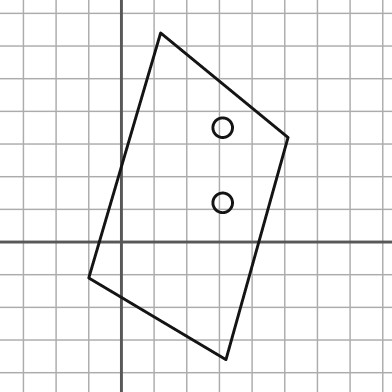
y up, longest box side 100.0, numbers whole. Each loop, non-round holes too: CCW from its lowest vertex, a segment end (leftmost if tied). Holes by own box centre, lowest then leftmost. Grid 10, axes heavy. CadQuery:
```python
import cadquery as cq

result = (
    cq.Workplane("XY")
    .moveTo(32.0, -36.0)
    .lineTo(51.0, 32.0)
    .lineTo(12.0, 64.0)
    .lineTo(-10.0, -11.0)
    .close()
    .moveTo(31.0, 12.0)
    .circle(3.0)
    .moveTo(31.0, 35.0)
    .circle(3.0)
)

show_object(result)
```